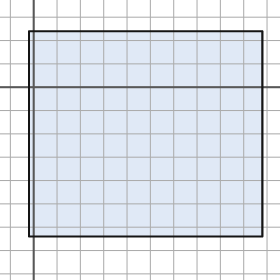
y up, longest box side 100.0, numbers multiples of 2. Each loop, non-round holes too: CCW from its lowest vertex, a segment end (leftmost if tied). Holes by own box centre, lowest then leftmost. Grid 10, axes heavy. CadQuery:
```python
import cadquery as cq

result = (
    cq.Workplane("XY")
    .moveTo(-2.0, -64.0)
    .lineTo(98.0, -64.0)
    .lineTo(98.0, 24.0)
    .lineTo(-2.0, 24.0)
    .close()
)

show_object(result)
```